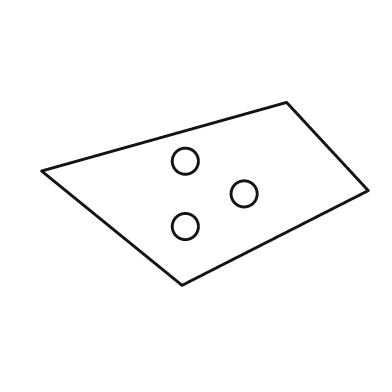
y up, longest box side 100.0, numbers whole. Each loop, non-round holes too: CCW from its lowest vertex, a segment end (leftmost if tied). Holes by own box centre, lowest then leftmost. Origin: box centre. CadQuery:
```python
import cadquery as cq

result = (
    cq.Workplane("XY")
    .moveTo(-7.0, -28.0)
    .lineTo(50.0, 1.0)
    .lineTo(25.0, 28.0)
    .lineTo(-50.0, 7.0)
    .close()
    .moveTo(-6.0, -10.0)
    .circle(4.0)
    .moveTo(12.0, 0.0)
    .circle(4.0)
    .moveTo(-6.0, 10.0)
    .circle(4.0)
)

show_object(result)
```